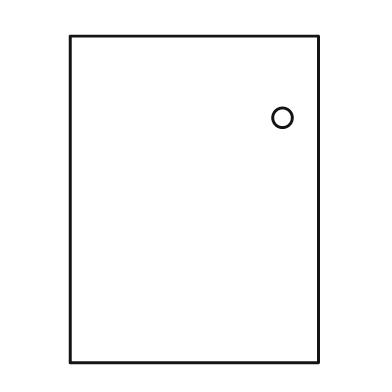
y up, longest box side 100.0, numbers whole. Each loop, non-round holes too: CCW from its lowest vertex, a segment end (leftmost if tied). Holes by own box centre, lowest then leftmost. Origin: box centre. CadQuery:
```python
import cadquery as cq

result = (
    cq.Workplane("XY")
    .moveTo(-38.0, -50.0)
    .lineTo(38.0, -50.0)
    .lineTo(38.0, 50.0)
    .lineTo(-38.0, 50.0)
    .close()
    .moveTo(27.0, 25.0)
    .circle(3.0)
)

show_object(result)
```